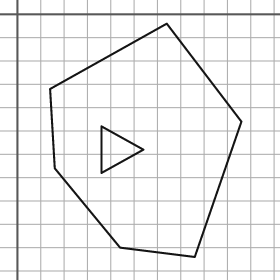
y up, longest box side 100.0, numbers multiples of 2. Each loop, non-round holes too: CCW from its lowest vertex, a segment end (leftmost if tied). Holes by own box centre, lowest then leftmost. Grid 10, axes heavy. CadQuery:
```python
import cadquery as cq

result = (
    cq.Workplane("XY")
    .moveTo(76.0, -104.0)
    .lineTo(96.0, -46.0)
    .lineTo(64.0, -4.0)
    .lineTo(14.0, -32.0)
    .lineTo(16.0, -66.0)
    .lineTo(44.0, -100.0)
    .close()
    .moveTo(36.0, -68.0)
    .lineTo(54.0, -58.0)
    .lineTo(36.0, -48.0)
    .close()
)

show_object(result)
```